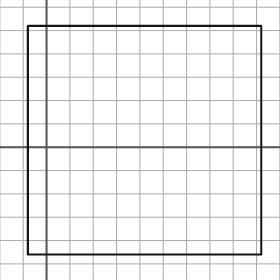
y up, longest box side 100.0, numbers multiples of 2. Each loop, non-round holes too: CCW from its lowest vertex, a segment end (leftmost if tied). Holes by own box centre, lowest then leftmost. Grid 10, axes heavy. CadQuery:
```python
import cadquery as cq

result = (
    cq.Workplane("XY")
    .moveTo(-8.0, -46.0)
    .lineTo(92.0, -46.0)
    .lineTo(92.0, 52.0)
    .lineTo(-8.0, 52.0)
    .close()
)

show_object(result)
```